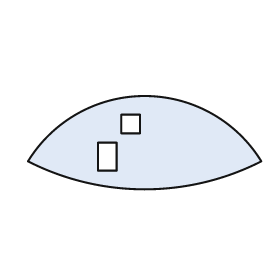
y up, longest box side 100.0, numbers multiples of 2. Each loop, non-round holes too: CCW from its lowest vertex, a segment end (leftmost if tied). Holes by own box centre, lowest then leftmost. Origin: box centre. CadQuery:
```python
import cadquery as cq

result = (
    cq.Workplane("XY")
    .moveTo(-50.0, -8.0)
    .threePointArc((0.0, -20.0), (50.0, -8.0))
    .threePointArc((0.0, 20.0), (-50.0, -8.0))
    .close()
    .moveTo(-20.0, -12.0)
    .lineTo(-12.0, -12.0)
    .lineTo(-12.0, 0.0)
    .lineTo(-20.0, 0.0)
    .close()
    .moveTo(-10.0, 4.0)
    .lineTo(-2.0, 4.0)
    .lineTo(-2.0, 12.0)
    .lineTo(-10.0, 12.0)
    .close()
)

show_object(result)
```